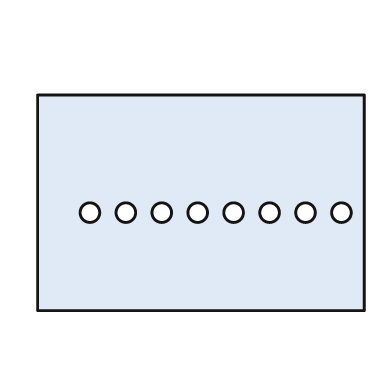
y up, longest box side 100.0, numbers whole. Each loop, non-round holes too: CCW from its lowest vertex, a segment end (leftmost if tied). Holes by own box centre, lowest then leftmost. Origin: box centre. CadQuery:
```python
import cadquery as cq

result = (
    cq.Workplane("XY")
    .moveTo(-50.0, -33.0)
    .lineTo(50.0, -33.0)
    .lineTo(50.0, 33.0)
    .lineTo(-50.0, 33.0)
    .close()
    .moveTo(-34.0, -3.0)
    .circle(3.0)
    .moveTo(-23.0, -3.0)
    .circle(3.0)
    .moveTo(-12.0, -3.0)
    .circle(3.0)
    .moveTo(-1.0, -3.0)
    .circle(3.0)
    .moveTo(10.0, -3.0)
    .circle(3.0)
    .moveTo(21.0, -3.0)
    .circle(3.0)
    .moveTo(32.0, -3.0)
    .circle(3.0)
    .moveTo(43.0, -3.0)
    .circle(3.0)
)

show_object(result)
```